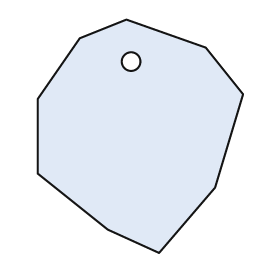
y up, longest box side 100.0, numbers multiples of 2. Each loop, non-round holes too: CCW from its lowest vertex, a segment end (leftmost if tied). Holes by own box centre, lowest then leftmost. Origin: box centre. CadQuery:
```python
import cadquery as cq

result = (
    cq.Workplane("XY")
    .moveTo(8.0, -50.0)
    .lineTo(32.0, -22.0)
    .lineTo(44.0, 18.0)
    .lineTo(28.0, 38.0)
    .lineTo(-6.0, 50.0)
    .lineTo(-26.0, 42.0)
    .lineTo(-44.0, 16.0)
    .lineTo(-44.0, -16.0)
    .lineTo(-14.0, -40.0)
    .close()
    .moveTo(-4.0, 32.0)
    .circle(4.0)
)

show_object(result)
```